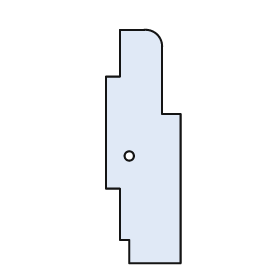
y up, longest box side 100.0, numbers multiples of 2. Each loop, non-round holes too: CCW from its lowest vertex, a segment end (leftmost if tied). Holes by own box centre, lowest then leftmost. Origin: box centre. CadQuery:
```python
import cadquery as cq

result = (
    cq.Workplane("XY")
    .moveTo(-6.0, -50.0)
    .lineTo(16.0, -50.0)
    .lineTo(16.0, 14.0)
    .lineTo(8.0, 14.0)
    .lineTo(8.0, 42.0)
    .threePointArc((6.0, 48.0), (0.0, 50.0))
    .lineTo(-10.0, 50.0)
    .lineTo(-10.0, 30.0)
    .lineTo(-16.0, 30.0)
    .lineTo(-16.0, -18.0)
    .lineTo(-10.0, -18.0)
    .lineTo(-10.0, -40.0)
    .lineTo(-6.0, -40.0)
    .close()
    .moveTo(-6.0, -4.0)
    .circle(2.0)
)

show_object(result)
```